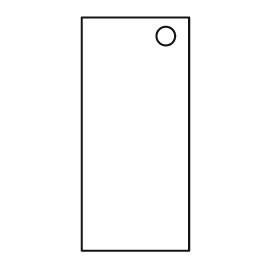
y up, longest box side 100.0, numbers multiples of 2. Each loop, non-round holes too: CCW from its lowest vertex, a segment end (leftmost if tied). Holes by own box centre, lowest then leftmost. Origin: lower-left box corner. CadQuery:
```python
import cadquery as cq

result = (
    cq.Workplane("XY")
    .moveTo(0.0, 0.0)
    .lineTo(46.0, 0.0)
    .lineTo(46.0, 100.0)
    .lineTo(0.0, 100.0)
    .close()
    .moveTo(36.0, 92.0)
    .circle(4.0)
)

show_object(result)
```